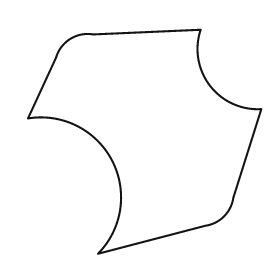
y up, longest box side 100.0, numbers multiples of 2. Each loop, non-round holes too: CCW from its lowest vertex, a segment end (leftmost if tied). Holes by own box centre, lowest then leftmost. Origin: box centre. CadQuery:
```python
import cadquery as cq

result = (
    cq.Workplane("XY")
    .moveTo(-20.0, -48.0)
    .lineTo(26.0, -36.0)
    .threePointArc((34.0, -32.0), (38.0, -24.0))
    .lineTo(50.0, 14.0)
    .threePointArc((28.0, 24.0), (24.0, 48.0))
    .lineTo(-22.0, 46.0)
    .threePointArc((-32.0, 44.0), (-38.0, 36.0))
    .lineTo(-50.0, 10.0)
    .threePointArc((-14.0, -8.0), (-20.0, -48.0))
    .close()
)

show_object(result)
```